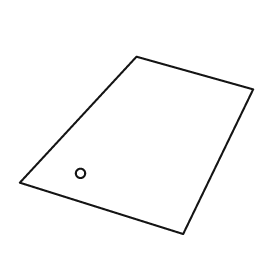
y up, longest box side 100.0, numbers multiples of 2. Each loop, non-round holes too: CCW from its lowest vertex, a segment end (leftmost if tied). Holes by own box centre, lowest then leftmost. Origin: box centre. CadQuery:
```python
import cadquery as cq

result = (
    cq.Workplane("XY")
    .moveTo(20.0, -38.0)
    .lineTo(50.0, 24.0)
    .lineTo(0.0, 38.0)
    .lineTo(-50.0, -16.0)
    .close()
    .moveTo(-24.0, -12.0)
    .circle(2.0)
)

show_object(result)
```